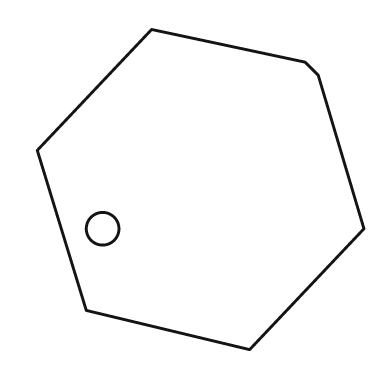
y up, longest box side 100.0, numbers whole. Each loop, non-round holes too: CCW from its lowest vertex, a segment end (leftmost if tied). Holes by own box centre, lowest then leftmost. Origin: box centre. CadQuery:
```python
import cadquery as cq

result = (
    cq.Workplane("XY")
    .moveTo(15.0, -49.0)
    .lineTo(50.0, -12.0)
    .lineTo(36.0, 35.0)
    .lineTo(32.0, 39.0)
    .lineTo(-15.0, 49.0)
    .lineTo(-50.0, 12.0)
    .lineTo(-35.0, -37.0)
    .close()
    .moveTo(-30.0, -12.0)
    .circle(5.0)
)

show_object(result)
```